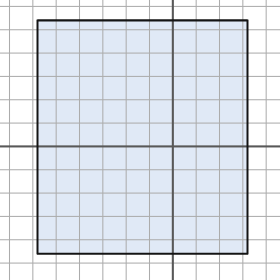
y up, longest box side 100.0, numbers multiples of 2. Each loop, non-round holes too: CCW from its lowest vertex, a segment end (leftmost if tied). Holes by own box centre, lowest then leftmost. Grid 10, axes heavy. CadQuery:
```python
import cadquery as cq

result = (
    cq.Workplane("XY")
    .moveTo(-58.0, -46.0)
    .lineTo(32.0, -46.0)
    .lineTo(32.0, 54.0)
    .lineTo(-58.0, 54.0)
    .close()
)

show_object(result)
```